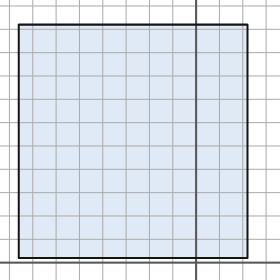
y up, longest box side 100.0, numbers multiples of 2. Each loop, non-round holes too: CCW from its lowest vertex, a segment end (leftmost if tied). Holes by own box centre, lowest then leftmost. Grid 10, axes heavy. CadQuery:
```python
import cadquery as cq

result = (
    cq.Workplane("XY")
    .moveTo(-76.0, 2.0)
    .lineTo(22.0, 2.0)
    .lineTo(22.0, 102.0)
    .lineTo(-76.0, 102.0)
    .close()
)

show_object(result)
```